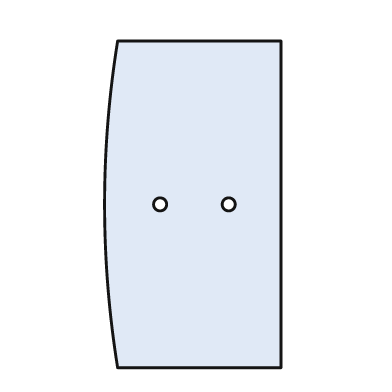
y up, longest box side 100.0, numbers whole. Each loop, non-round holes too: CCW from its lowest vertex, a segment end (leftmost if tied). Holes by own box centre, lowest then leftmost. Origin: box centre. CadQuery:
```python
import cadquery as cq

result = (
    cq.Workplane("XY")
    .moveTo(-23.0, -50.0)
    .lineTo(27.0, -50.0)
    .lineTo(27.0, 50.0)
    .lineTo(-23.0, 50.0)
    .threePointArc((-27.0, 0.0), (-23.0, -50.0))
    .close()
    .moveTo(-10.0, 0.0)
    .circle(2.0)
    .moveTo(11.0, 0.0)
    .circle(2.0)
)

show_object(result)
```